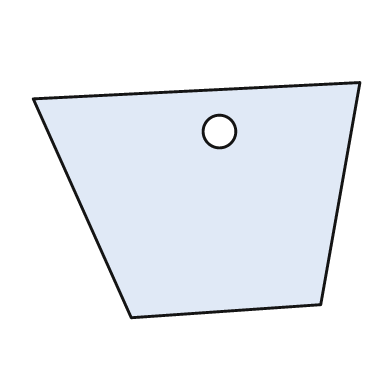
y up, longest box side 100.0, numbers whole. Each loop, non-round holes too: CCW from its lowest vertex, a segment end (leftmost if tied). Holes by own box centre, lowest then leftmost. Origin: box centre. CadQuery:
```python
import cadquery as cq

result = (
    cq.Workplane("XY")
    .moveTo(-20.0, -36.0)
    .lineTo(38.0, -32.0)
    .lineTo(50.0, 36.0)
    .lineTo(-50.0, 31.0)
    .close()
    .moveTo(7.0, 21.0)
    .circle(5.0)
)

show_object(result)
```